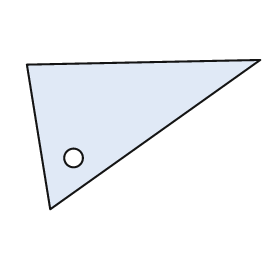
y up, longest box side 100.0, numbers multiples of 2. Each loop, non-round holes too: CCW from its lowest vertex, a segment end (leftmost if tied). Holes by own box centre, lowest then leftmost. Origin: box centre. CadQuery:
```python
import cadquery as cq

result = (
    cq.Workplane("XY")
    .moveTo(-40.0, -32.0)
    .lineTo(50.0, 32.0)
    .lineTo(-50.0, 30.0)
    .close()
    .moveTo(-30.0, -10.0)
    .circle(4.0)
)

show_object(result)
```